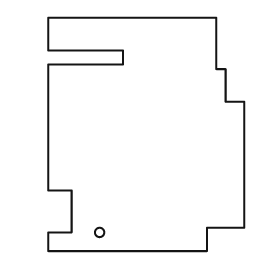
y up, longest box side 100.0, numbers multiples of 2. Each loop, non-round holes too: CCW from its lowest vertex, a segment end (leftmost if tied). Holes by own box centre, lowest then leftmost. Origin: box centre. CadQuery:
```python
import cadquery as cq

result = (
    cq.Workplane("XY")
    .moveTo(-42.0, -50.0)
    .lineTo(26.0, -50.0)
    .lineTo(26.0, -40.0)
    .lineTo(42.0, -40.0)
    .lineTo(42.0, 14.0)
    .lineTo(34.0, 14.0)
    .lineTo(34.0, 28.0)
    .lineTo(30.0, 28.0)
    .lineTo(30.0, 50.0)
    .lineTo(-42.0, 50.0)
    .lineTo(-42.0, 36.0)
    .lineTo(-10.0, 36.0)
    .lineTo(-10.0, 30.0)
    .lineTo(-42.0, 30.0)
    .lineTo(-42.0, -24.0)
    .lineTo(-32.0, -24.0)
    .lineTo(-32.0, -42.0)
    .lineTo(-42.0, -42.0)
    .close()
    .moveTo(-20.0, -42.0)
    .circle(2.0)
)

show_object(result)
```